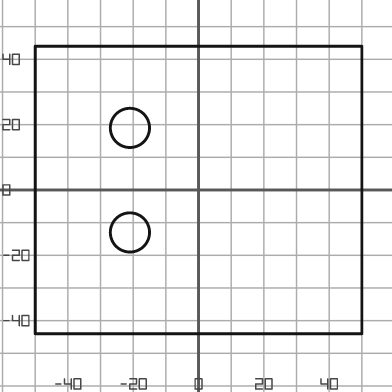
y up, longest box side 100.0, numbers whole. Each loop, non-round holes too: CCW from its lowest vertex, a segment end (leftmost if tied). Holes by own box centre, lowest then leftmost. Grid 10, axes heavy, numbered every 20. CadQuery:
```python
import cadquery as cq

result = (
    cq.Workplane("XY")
    .moveTo(-50.0, -44.0)
    .lineTo(50.0, -44.0)
    .lineTo(50.0, 44.0)
    .lineTo(-50.0, 44.0)
    .close()
    .moveTo(-21.0, -13.0)
    .circle(6.0)
    .moveTo(-21.0, 19.0)
    .circle(6.0)
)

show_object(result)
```